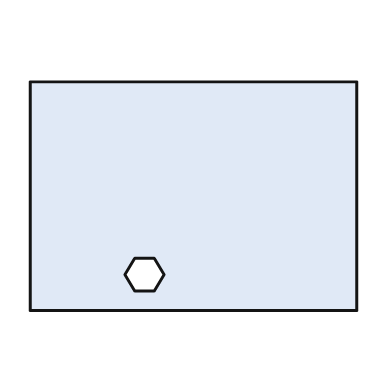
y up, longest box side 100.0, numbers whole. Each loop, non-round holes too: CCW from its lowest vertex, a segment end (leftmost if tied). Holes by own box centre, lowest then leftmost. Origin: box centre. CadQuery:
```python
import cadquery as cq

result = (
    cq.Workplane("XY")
    .moveTo(-50.0, -35.0)
    .lineTo(50.0, -35.0)
    .lineTo(50.0, 35.0)
    .lineTo(-50.0, 35.0)
    .close()
    .moveTo(-18.0, -29.0)
    .lineTo(-12.0, -29.0)
    .lineTo(-9.0, -24.0)
    .lineTo(-12.0, -19.0)
    .lineTo(-18.0, -19.0)
    .lineTo(-21.0, -24.0)
    .close()
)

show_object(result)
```